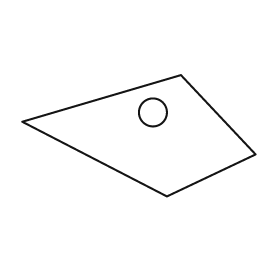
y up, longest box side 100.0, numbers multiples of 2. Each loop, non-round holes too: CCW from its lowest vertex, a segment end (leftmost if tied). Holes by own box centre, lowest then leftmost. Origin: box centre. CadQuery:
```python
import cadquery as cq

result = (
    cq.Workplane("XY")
    .moveTo(12.0, -26.0)
    .lineTo(50.0, -8.0)
    .lineTo(18.0, 26.0)
    .lineTo(-50.0, 6.0)
    .close()
    .moveTo(6.0, 10.0)
    .circle(6.0)
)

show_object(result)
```